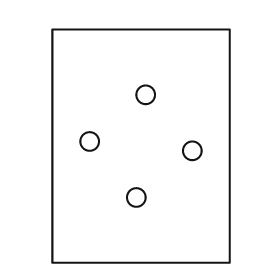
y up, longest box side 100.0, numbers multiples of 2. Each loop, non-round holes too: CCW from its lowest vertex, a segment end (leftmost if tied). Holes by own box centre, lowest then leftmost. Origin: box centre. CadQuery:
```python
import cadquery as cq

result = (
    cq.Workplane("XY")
    .moveTo(-38.0, -50.0)
    .lineTo(38.0, -50.0)
    .lineTo(38.0, 50.0)
    .lineTo(-38.0, 50.0)
    .close()
    .moveTo(-2.0, -22.0)
    .circle(4.0)
    .moveTo(22.0, -2.0)
    .circle(4.0)
    .moveTo(-22.0, 2.0)
    .circle(4.0)
    .moveTo(2.0, 22.0)
    .circle(4.0)
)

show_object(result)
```